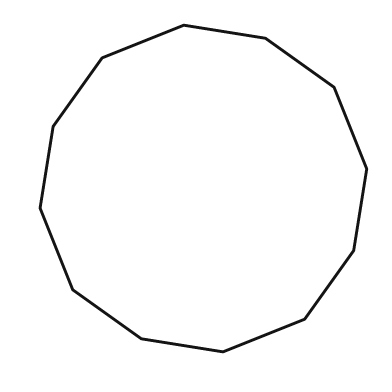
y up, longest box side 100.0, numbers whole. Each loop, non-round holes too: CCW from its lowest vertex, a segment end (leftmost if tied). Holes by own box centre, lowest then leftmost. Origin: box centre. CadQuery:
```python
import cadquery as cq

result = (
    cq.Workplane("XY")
    .moveTo(6.0, -50.0)
    .lineTo(31.0, -40.0)
    .lineTo(46.0, -19.0)
    .lineTo(50.0, 6.0)
    .lineTo(40.0, 31.0)
    .lineTo(19.0, 46.0)
    .lineTo(-6.0, 50.0)
    .lineTo(-31.0, 40.0)
    .lineTo(-46.0, 19.0)
    .lineTo(-50.0, -6.0)
    .lineTo(-40.0, -31.0)
    .lineTo(-19.0, -46.0)
    .close()
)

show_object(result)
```